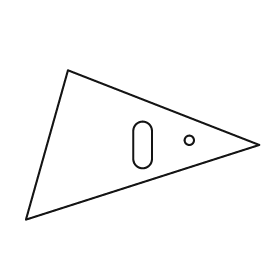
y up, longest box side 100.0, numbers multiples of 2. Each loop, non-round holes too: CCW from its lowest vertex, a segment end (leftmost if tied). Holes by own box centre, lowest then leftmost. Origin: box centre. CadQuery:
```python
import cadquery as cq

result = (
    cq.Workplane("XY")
    .moveTo(-50.0, -32.0)
    .lineTo(50.0, 0.0)
    .lineTo(-32.0, 32.0)
    .close()
    .moveTo(-4.0, -6.0)
    .threePointArc((0.0, -10.0), (4.0, -6.0))
    .lineTo(4.0, 6.0)
    .threePointArc((0.0, 10.0), (-4.0, 6.0))
    .close()
    .moveTo(20.0, 2.0)
    .circle(2.0)
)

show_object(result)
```